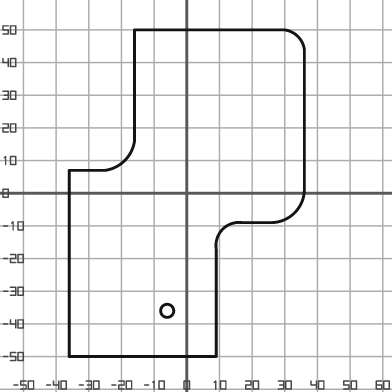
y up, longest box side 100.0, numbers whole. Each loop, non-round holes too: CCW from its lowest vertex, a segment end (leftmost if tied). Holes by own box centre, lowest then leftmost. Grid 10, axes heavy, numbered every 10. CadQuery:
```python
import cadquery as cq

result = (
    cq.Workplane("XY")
    .moveTo(-36.0, -50.0)
    .lineTo(9.0, -50.0)
    .lineTo(9.0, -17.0)
    .threePointArc((11.0, -11.0), (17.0, -9.0))
    .lineTo(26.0, -9.0)
    .threePointArc((33.0, -6.0), (36.0, 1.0))
    .lineTo(36.0, 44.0)
    .threePointArc((34.0, 48.0), (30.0, 50.0))
    .lineTo(-16.0, 50.0)
    .lineTo(-16.0, 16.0)
    .threePointArc((-19.0, 10.0), (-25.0, 7.0))
    .lineTo(-36.0, 7.0)
    .close()
    .moveTo(-6.0, -36.0)
    .circle(2.0)
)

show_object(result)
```